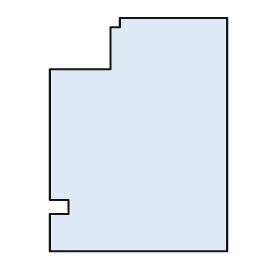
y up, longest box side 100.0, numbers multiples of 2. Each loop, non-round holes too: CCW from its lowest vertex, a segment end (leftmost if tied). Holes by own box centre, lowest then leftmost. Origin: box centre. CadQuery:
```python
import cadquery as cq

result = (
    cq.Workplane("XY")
    .moveTo(-38.0, -50.0)
    .lineTo(38.0, -50.0)
    .lineTo(38.0, 50.0)
    .lineTo(-8.0, 50.0)
    .lineTo(-8.0, 46.0)
    .lineTo(-12.0, 46.0)
    .lineTo(-12.0, 28.0)
    .lineTo(-38.0, 28.0)
    .lineTo(-38.0, -28.0)
    .lineTo(-30.0, -28.0)
    .lineTo(-30.0, -34.0)
    .lineTo(-38.0, -34.0)
    .close()
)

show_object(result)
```